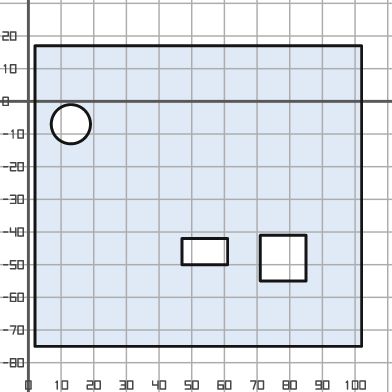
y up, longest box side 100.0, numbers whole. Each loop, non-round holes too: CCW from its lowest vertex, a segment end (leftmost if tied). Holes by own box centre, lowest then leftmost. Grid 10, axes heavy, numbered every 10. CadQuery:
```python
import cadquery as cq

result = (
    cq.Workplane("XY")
    .moveTo(2.0, -75.0)
    .lineTo(102.0, -75.0)
    .lineTo(102.0, 17.0)
    .lineTo(2.0, 17.0)
    .close()
    .moveTo(71.0, -55.0)
    .lineTo(85.0, -55.0)
    .lineTo(85.0, -41.0)
    .lineTo(71.0, -41.0)
    .close()
    .moveTo(47.0, -50.0)
    .lineTo(61.0, -50.0)
    .lineTo(61.0, -42.0)
    .lineTo(47.0, -42.0)
    .close()
    .moveTo(13.0, -7.0)
    .circle(6.0)
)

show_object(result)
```